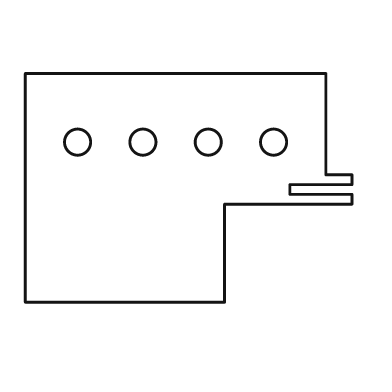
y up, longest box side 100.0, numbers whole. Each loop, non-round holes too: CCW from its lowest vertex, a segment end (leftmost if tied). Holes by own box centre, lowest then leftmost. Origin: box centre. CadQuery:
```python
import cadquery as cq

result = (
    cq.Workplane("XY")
    .moveTo(-50.0, -35.0)
    .lineTo(11.0, -35.0)
    .lineTo(11.0, -5.0)
    .lineTo(50.0, -5.0)
    .lineTo(50.0, -2.0)
    .lineTo(31.0, -2.0)
    .lineTo(31.0, 1.0)
    .lineTo(50.0, 1.0)
    .lineTo(50.0, 4.0)
    .lineTo(42.0, 4.0)
    .lineTo(42.0, 35.0)
    .lineTo(-50.0, 35.0)
    .close()
    .moveTo(-34.0, 14.0)
    .circle(4.0)
    .moveTo(-14.0, 14.0)
    .circle(4.0)
    .moveTo(6.0, 14.0)
    .circle(4.0)
    .moveTo(26.0, 14.0)
    .circle(4.0)
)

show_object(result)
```